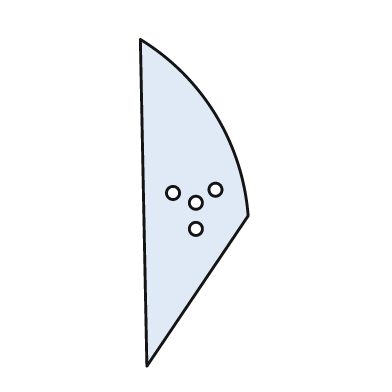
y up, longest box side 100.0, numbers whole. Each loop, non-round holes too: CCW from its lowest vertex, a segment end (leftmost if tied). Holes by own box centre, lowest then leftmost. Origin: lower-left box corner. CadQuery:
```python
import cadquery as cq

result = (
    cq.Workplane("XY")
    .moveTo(2.0, 0.0)
    .lineTo(33.0, 46.0)
    .threePointArc((23.0, 77.0), (0.0, 100.0))
    .close()
    .moveTo(17.0, 42.0)
    .circle(2.0)
    .moveTo(17.0, 50.0)
    .circle(2.0)
    .moveTo(10.0, 53.0)
    .circle(2.0)
    .moveTo(23.0, 54.0)
    .circle(2.0)
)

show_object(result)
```